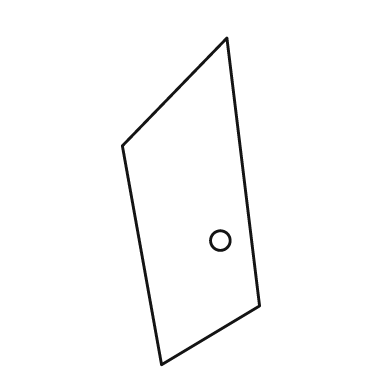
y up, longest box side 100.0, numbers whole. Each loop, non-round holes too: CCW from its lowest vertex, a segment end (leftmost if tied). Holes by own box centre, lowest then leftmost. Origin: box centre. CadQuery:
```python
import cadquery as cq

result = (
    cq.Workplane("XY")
    .moveTo(-9.0, -50.0)
    .lineTo(21.0, -32.0)
    .lineTo(11.0, 50.0)
    .lineTo(-21.0, 17.0)
    .close()
    .moveTo(9.0, -12.0)
    .circle(3.0)
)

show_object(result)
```